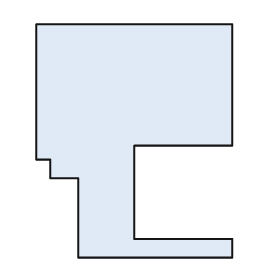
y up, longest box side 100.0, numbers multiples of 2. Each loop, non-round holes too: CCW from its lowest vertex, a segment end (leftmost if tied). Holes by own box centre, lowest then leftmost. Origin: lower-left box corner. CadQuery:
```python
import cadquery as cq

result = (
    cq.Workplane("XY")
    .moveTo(18.0, 0.0)
    .lineTo(84.0, 0.0)
    .lineTo(84.0, 8.0)
    .lineTo(42.0, 8.0)
    .lineTo(42.0, 48.0)
    .lineTo(84.0, 48.0)
    .lineTo(84.0, 100.0)
    .lineTo(0.0, 100.0)
    .lineTo(0.0, 42.0)
    .lineTo(6.0, 42.0)
    .lineTo(6.0, 34.0)
    .lineTo(18.0, 34.0)
    .close()
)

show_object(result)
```